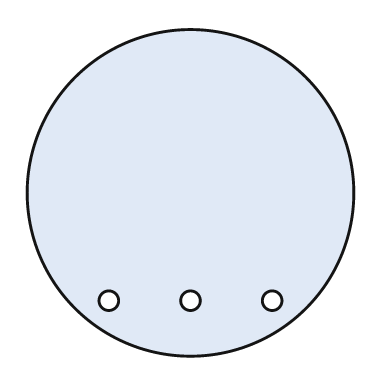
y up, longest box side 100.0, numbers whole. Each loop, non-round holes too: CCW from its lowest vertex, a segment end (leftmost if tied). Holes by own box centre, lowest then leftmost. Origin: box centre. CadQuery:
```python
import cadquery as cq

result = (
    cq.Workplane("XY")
    .moveTo(0.0, 0.0)
    .circle(50.0)
    .moveTo(-25.0, -33.0)
    .circle(3.0)
    .moveTo(0.0, -33.0)
    .circle(3.0)
    .moveTo(25.0, -33.0)
    .circle(3.0)
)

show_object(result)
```